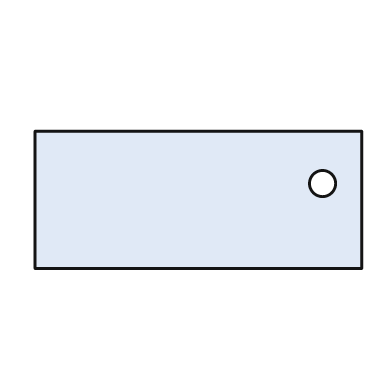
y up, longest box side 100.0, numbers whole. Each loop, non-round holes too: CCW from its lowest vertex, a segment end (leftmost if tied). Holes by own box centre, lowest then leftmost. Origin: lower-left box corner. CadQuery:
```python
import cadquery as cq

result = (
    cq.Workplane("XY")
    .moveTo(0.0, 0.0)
    .lineTo(100.0, 0.0)
    .lineTo(100.0, 42.0)
    .lineTo(0.0, 42.0)
    .close()
    .moveTo(88.0, 26.0)
    .circle(4.0)
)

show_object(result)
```